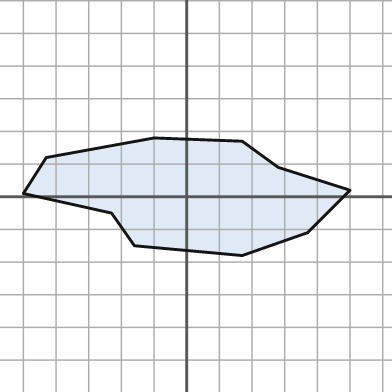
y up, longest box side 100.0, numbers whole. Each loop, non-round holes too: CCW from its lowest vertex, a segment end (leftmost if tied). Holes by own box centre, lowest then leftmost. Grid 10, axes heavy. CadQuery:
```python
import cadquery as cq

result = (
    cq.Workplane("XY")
    .moveTo(17.0, -18.0)
    .lineTo(37.0, -11.0)
    .lineTo(50.0, 2.0)
    .lineTo(28.0, 9.0)
    .lineTo(17.0, 17.0)
    .lineTo(-10.0, 18.0)
    .lineTo(-43.0, 12.0)
    .lineTo(-50.0, 1.0)
    .lineTo(-23.0, -5.0)
    .lineTo(-16.0, -15.0)
    .close()
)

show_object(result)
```